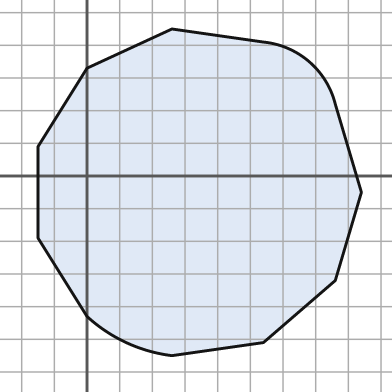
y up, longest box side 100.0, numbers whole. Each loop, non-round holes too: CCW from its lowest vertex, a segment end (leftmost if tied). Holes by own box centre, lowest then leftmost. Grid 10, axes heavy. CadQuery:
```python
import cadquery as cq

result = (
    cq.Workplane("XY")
    .moveTo(26.0, -55.0)
    .lineTo(54.0, -51.0)
    .lineTo(76.0, -32.0)
    .lineTo(84.0, -5.0)
    .lineTo(76.0, 22.0)
    .threePointArc((68.0, 35.0), (54.0, 41.0))
    .lineTo(26.0, 45.0)
    .lineTo(0.0, 33.0)
    .lineTo(-15.0, 9.0)
    .lineTo(-15.0, -19.0)
    .lineTo(0.0, -43.0)
    .threePointArc((12.0, -51.0), (26.0, -55.0))
    .close()
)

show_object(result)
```